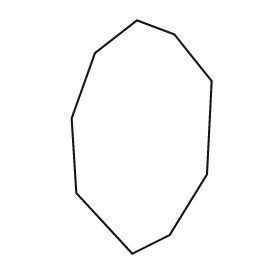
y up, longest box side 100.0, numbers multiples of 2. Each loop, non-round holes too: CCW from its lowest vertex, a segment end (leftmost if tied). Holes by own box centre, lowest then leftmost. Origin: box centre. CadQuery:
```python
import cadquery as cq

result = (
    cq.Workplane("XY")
    .moveTo(-4.0, -50.0)
    .lineTo(12.0, -42.0)
    .lineTo(28.0, -16.0)
    .lineTo(30.0, 24.0)
    .lineTo(14.0, 44.0)
    .lineTo(-2.0, 50.0)
    .lineTo(-20.0, 36.0)
    .lineTo(-30.0, 8.0)
    .lineTo(-28.0, -24.0)
    .close()
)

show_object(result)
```